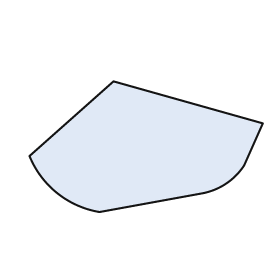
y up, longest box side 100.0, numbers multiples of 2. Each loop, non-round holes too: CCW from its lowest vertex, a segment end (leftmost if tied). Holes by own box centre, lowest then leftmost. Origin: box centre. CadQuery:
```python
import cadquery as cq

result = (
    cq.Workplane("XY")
    .moveTo(-20.0, -28.0)
    .lineTo(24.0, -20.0)
    .threePointArc((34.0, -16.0), (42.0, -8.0))
    .lineTo(50.0, 10.0)
    .lineTo(-14.0, 28.0)
    .lineTo(-50.0, -4.0)
    .threePointArc((-38.0, -20.0), (-20.0, -28.0))
    .close()
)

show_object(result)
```